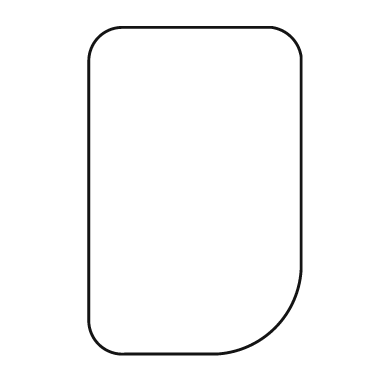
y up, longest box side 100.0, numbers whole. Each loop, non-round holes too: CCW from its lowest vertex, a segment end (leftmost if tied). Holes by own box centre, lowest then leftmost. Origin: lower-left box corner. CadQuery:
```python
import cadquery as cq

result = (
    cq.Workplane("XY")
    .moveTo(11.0, 0.0)
    .lineTo(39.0, 0.0)
    .threePointArc((57.0, 8.0), (65.0, 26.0))
    .lineTo(65.0, 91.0)
    .threePointArc((62.0, 97.0), (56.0, 100.0))
    .lineTo(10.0, 100.0)
    .threePointArc((3.0, 97.0), (0.0, 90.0))
    .lineTo(0.0, 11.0)
    .threePointArc((3.0, 3.0), (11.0, 0.0))
    .close()
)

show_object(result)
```